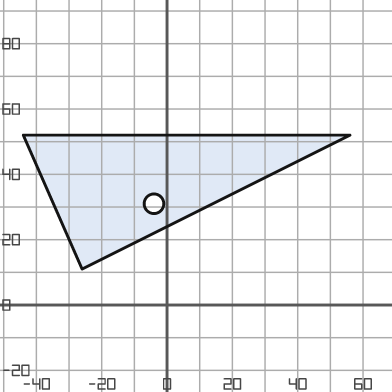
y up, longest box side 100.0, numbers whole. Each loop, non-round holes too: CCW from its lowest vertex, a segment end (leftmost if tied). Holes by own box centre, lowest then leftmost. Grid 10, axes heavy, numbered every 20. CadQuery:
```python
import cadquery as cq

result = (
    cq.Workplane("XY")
    .moveTo(-26.0, 11.0)
    .lineTo(56.0, 52.0)
    .lineTo(-44.0, 52.0)
    .close()
    .moveTo(-4.0, 31.0)
    .circle(3.0)
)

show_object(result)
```